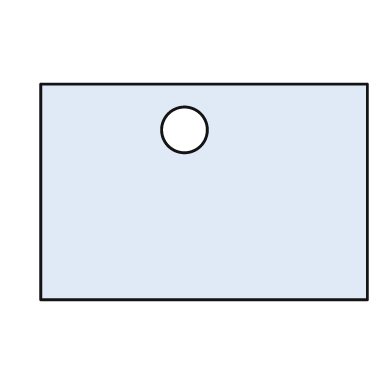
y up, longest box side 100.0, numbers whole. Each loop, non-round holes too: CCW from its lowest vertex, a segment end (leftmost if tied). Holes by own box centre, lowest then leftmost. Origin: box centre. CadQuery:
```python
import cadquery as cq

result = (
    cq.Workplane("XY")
    .moveTo(-50.0, -33.0)
    .lineTo(50.0, -33.0)
    .lineTo(50.0, 33.0)
    .lineTo(-50.0, 33.0)
    .close()
    .moveTo(-6.0, 19.0)
    .circle(7.0)
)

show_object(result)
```